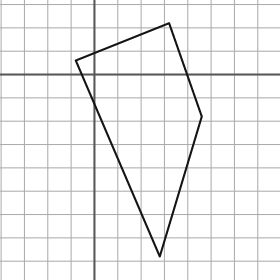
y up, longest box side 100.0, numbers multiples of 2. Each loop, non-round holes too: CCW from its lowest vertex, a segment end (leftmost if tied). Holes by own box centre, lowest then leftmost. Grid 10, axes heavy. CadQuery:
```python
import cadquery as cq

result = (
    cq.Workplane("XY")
    .moveTo(28.0, -78.0)
    .lineTo(46.0, -18.0)
    .lineTo(32.0, 22.0)
    .lineTo(-8.0, 6.0)
    .close()
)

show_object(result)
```